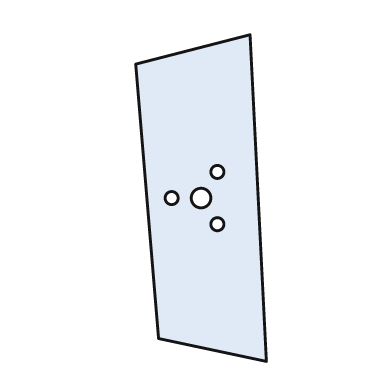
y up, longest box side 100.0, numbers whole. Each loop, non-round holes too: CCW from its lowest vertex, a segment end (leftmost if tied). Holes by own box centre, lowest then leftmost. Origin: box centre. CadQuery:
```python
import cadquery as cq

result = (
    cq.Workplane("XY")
    .moveTo(20.0, -50.0)
    .lineTo(15.0, 50.0)
    .lineTo(-20.0, 41.0)
    .lineTo(-13.0, -43.0)
    .close()
    .moveTo(5.0, -8.0)
    .circle(2.0)
    .moveTo(-9.0, 0.0)
    .circle(2.0)
    .moveTo(0.0, 0.0)
    .circle(3.0)
    .moveTo(5.0, 8.0)
    .circle(2.0)
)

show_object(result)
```